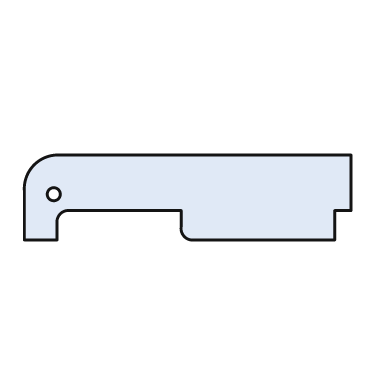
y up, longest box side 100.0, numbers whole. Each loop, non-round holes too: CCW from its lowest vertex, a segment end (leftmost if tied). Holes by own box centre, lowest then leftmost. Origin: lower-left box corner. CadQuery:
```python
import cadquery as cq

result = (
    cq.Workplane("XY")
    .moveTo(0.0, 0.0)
    .lineTo(10.0, 0.0)
    .lineTo(10.0, 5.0)
    .threePointArc((11.0, 8.0), (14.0, 9.0))
    .lineTo(48.0, 9.0)
    .lineTo(48.0, 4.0)
    .threePointArc((49.0, 1.0), (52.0, 0.0))
    .lineTo(95.0, 0.0)
    .lineTo(95.0, 9.0)
    .lineTo(100.0, 9.0)
    .lineTo(100.0, 26.0)
    .lineTo(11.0, 26.0)
    .threePointArc((3.0, 23.0), (0.0, 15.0))
    .close()
    .moveTo(9.0, 14.0)
    .circle(2.0)
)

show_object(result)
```